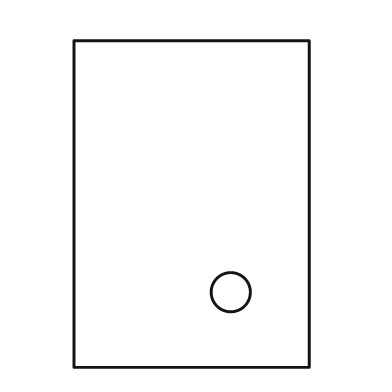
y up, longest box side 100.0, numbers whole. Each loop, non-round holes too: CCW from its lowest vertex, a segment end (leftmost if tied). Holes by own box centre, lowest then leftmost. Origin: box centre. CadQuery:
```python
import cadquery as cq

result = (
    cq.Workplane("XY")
    .moveTo(-36.0, -50.0)
    .lineTo(36.0, -50.0)
    .lineTo(36.0, 50.0)
    .lineTo(-36.0, 50.0)
    .close()
    .moveTo(12.0, -27.0)
    .circle(6.0)
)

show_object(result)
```